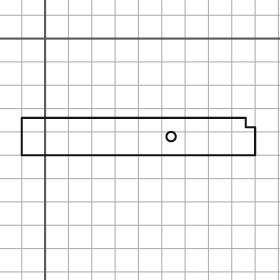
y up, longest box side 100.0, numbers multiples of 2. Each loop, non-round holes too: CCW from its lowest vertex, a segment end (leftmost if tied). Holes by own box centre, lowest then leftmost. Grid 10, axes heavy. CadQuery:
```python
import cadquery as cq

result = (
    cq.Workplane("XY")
    .moveTo(-10.0, -50.0)
    .lineTo(90.0, -50.0)
    .lineTo(90.0, -38.0)
    .lineTo(86.0, -38.0)
    .lineTo(86.0, -34.0)
    .lineTo(-10.0, -34.0)
    .close()
    .moveTo(54.0, -42.0)
    .circle(2.0)
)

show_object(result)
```